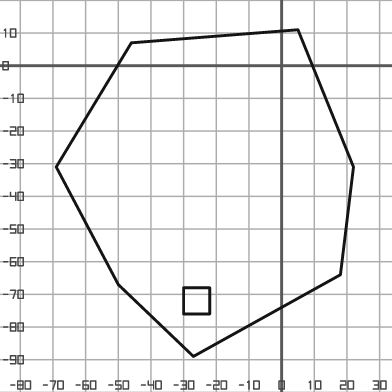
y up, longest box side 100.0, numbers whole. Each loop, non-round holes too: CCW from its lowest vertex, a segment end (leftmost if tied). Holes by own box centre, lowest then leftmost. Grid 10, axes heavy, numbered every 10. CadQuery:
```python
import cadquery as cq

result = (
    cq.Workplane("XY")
    .moveTo(-27.0, -89.0)
    .lineTo(18.0, -64.0)
    .lineTo(22.0, -31.0)
    .lineTo(5.0, 11.0)
    .lineTo(-46.0, 7.0)
    .lineTo(-69.0, -31.0)
    .lineTo(-50.0, -67.0)
    .close()
    .moveTo(-30.0, -76.0)
    .lineTo(-22.0, -76.0)
    .lineTo(-22.0, -68.0)
    .lineTo(-30.0, -68.0)
    .close()
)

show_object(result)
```